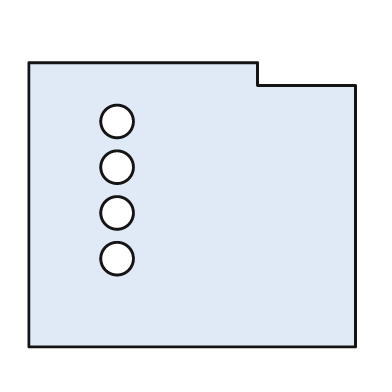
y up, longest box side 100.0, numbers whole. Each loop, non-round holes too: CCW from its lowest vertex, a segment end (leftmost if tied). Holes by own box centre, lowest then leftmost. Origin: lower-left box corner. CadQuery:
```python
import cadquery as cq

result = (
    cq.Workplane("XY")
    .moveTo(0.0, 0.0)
    .lineTo(100.0, 0.0)
    .lineTo(100.0, 80.0)
    .lineTo(70.0, 80.0)
    .lineTo(70.0, 87.0)
    .lineTo(0.0, 87.0)
    .close()
    .moveTo(27.0, 27.0)
    .circle(5.0)
    .moveTo(27.0, 41.0)
    .circle(5.0)
    .moveTo(27.0, 55.0)
    .circle(5.0)
    .moveTo(27.0, 69.0)
    .circle(5.0)
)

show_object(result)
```